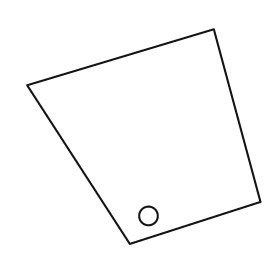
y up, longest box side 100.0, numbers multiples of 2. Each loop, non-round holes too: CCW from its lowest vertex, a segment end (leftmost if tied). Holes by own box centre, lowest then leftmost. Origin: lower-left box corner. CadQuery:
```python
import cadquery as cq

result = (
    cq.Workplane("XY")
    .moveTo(44.0, 0.0)
    .lineTo(100.0, 18.0)
    .lineTo(80.0, 92.0)
    .lineTo(0.0, 68.0)
    .close()
    .moveTo(52.0, 12.0)
    .circle(4.0)
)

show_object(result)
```